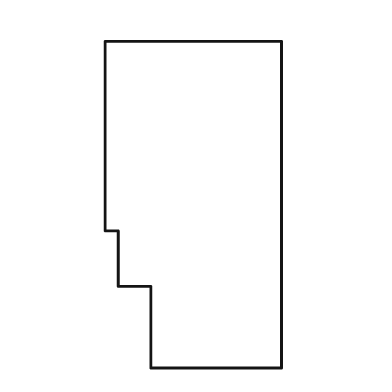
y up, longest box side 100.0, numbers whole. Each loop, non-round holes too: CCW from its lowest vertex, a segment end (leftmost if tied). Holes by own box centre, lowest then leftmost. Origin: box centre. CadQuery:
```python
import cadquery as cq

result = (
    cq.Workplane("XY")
    .moveTo(-13.0, -50.0)
    .lineTo(27.0, -50.0)
    .lineTo(27.0, 50.0)
    .lineTo(-27.0, 50.0)
    .lineTo(-27.0, -8.0)
    .lineTo(-23.0, -8.0)
    .lineTo(-23.0, -25.0)
    .lineTo(-13.0, -25.0)
    .close()
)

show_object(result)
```